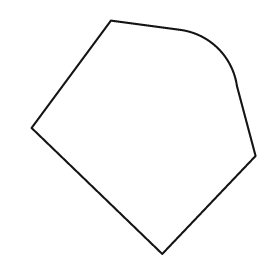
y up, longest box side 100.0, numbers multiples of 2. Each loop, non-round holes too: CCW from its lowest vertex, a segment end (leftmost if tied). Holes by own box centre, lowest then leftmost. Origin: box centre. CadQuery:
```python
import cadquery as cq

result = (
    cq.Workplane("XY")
    .moveTo(8.0, -50.0)
    .lineTo(48.0, -8.0)
    .lineTo(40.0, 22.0)
    .threePointArc((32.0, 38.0), (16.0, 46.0))
    .lineTo(-14.0, 50.0)
    .lineTo(-48.0, 4.0)
    .close()
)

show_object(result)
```